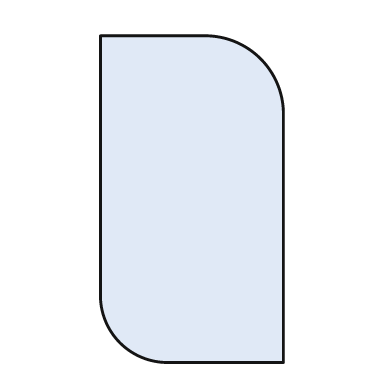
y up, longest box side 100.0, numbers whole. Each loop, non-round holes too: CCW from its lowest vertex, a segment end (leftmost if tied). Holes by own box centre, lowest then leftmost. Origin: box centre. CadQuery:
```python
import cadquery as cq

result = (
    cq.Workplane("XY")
    .moveTo(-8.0, -50.0)
    .lineTo(28.0, -50.0)
    .lineTo(28.0, 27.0)
    .threePointArc((21.0, 43.0), (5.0, 50.0))
    .lineTo(-28.0, 50.0)
    .lineTo(-28.0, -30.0)
    .threePointArc((-22.0, -44.0), (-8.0, -50.0))
    .close()
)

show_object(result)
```